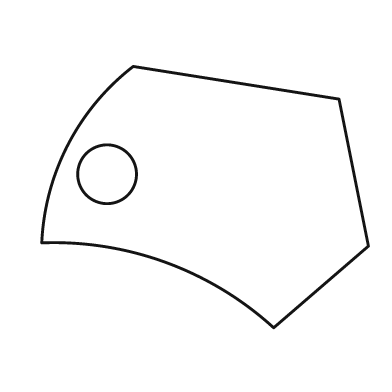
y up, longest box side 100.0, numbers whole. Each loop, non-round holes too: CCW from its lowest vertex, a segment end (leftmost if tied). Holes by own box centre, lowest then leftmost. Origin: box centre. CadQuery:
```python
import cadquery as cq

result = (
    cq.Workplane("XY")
    .moveTo(21.0, -40.0)
    .lineTo(50.0, -15.0)
    .lineTo(41.0, 30.0)
    .lineTo(-22.0, 40.0)
    .threePointArc((-42.0, 16.0), (-50.0, -14.0))
    .threePointArc((-12.0, -20.0), (21.0, -40.0))
    .close()
    .moveTo(-30.0, 7.0)
    .circle(9.0)
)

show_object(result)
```